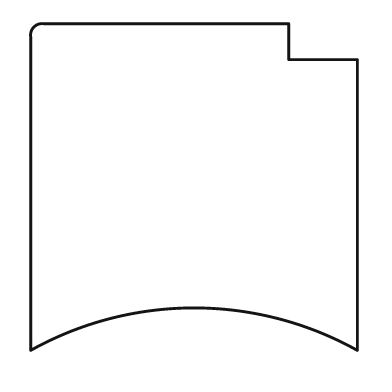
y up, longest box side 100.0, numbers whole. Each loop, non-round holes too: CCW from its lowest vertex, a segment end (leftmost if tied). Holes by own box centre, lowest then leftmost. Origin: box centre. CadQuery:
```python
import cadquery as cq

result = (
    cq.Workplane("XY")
    .moveTo(-50.0, -50.0)
    .threePointArc((0.0, -37.0), (50.0, -50.0))
    .lineTo(50.0, 39.0)
    .lineTo(29.0, 39.0)
    .lineTo(29.0, 50.0)
    .lineTo(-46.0, 50.0)
    .threePointArc((-49.0, 49.0), (-50.0, 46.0))
    .close()
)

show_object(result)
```